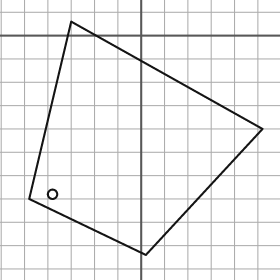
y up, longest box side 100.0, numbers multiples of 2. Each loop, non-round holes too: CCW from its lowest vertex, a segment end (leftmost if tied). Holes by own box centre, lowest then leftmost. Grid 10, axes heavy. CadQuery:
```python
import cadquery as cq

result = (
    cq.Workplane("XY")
    .moveTo(2.0, -94.0)
    .lineTo(52.0, -40.0)
    .lineTo(-30.0, 6.0)
    .lineTo(-48.0, -70.0)
    .close()
    .moveTo(-38.0, -68.0)
    .circle(2.0)
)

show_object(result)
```